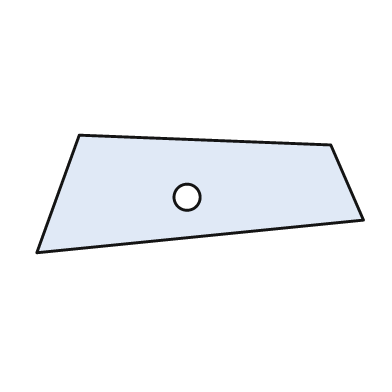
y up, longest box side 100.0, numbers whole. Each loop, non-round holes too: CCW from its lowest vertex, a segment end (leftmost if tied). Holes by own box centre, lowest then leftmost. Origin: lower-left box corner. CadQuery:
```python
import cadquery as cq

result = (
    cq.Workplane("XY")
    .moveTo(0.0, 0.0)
    .lineTo(100.0, 10.0)
    .lineTo(90.0, 33.0)
    .lineTo(13.0, 36.0)
    .close()
    .moveTo(46.0, 17.0)
    .circle(4.0)
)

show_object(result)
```